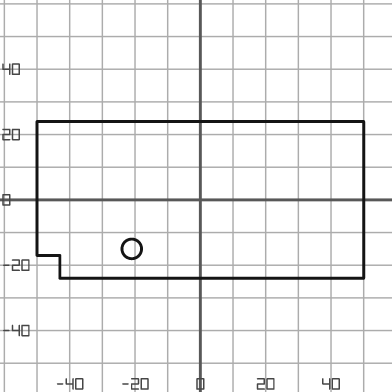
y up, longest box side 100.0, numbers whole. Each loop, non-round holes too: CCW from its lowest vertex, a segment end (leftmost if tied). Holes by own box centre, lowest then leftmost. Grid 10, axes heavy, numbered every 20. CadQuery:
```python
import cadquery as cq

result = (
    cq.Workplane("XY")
    .moveTo(-43.0, -24.0)
    .lineTo(50.0, -24.0)
    .lineTo(50.0, 24.0)
    .lineTo(-50.0, 24.0)
    .lineTo(-50.0, -17.0)
    .lineTo(-43.0, -17.0)
    .close()
    .moveTo(-21.0, -15.0)
    .circle(3.0)
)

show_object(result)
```